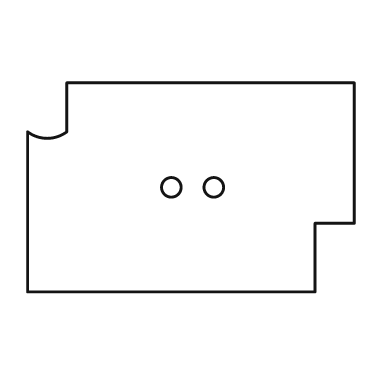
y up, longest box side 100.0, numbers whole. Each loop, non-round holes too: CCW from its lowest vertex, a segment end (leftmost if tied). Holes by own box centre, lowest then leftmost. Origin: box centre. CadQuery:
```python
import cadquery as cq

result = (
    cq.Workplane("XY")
    .moveTo(-50.0, -32.0)
    .lineTo(38.0, -32.0)
    .lineTo(38.0, -11.0)
    .lineTo(50.0, -11.0)
    .lineTo(50.0, 32.0)
    .lineTo(-38.0, 32.0)
    .lineTo(-38.0, 17.0)
    .threePointArc((-44.0, 15.0), (-50.0, 17.0))
    .close()
    .moveTo(-6.0, 0.0)
    .circle(3.0)
    .moveTo(7.0, 0.0)
    .circle(3.0)
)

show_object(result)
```